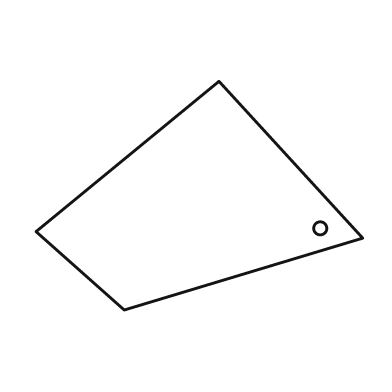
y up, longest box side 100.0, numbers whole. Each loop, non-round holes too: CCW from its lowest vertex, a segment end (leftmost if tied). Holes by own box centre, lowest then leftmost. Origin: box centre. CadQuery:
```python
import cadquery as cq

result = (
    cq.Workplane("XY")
    .moveTo(-23.0, -35.0)
    .lineTo(50.0, -13.0)
    .lineTo(6.0, 35.0)
    .lineTo(-50.0, -11.0)
    .close()
    .moveTo(37.0, -10.0)
    .circle(2.0)
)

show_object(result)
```